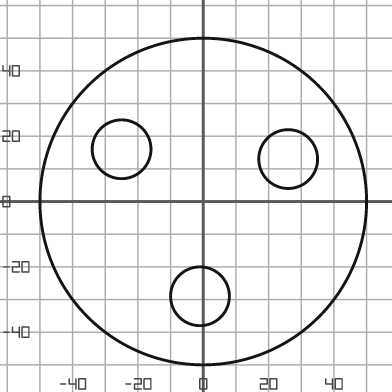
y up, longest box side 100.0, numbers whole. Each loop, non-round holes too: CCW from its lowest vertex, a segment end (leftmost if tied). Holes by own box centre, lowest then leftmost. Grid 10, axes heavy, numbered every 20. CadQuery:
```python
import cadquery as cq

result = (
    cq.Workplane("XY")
    .moveTo(0.0, 0.0)
    .circle(50.0)
    .moveTo(-1.0, -29.0)
    .circle(9.0)
    .moveTo(26.0, 13.0)
    .circle(9.0)
    .moveTo(-25.0, 16.0)
    .circle(9.0)
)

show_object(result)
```